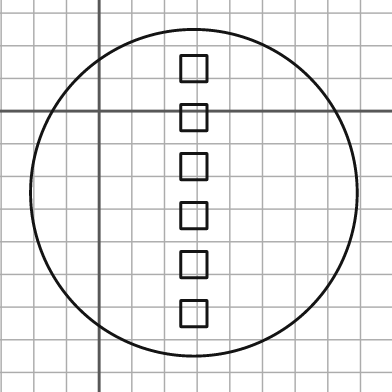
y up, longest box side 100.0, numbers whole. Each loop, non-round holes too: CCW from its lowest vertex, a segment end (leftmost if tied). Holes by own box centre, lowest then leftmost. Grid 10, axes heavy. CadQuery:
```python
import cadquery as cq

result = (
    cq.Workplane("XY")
    .moveTo(29.0, -25.0)
    .circle(50.0)
    .moveTo(25.0, -66.0)
    .lineTo(33.0, -66.0)
    .lineTo(33.0, -58.0)
    .lineTo(25.0, -58.0)
    .close()
    .moveTo(25.0, -51.0)
    .lineTo(33.0, -51.0)
    .lineTo(33.0, -43.0)
    .lineTo(25.0, -43.0)
    .close()
    .moveTo(25.0, -36.0)
    .lineTo(33.0, -36.0)
    .lineTo(33.0, -28.0)
    .lineTo(25.0, -28.0)
    .close()
    .moveTo(25.0, -21.0)
    .lineTo(33.0, -21.0)
    .lineTo(33.0, -13.0)
    .lineTo(25.0, -13.0)
    .close()
    .moveTo(25.0, -6.0)
    .lineTo(33.0, -6.0)
    .lineTo(33.0, 2.0)
    .lineTo(25.0, 2.0)
    .close()
    .moveTo(25.0, 9.0)
    .lineTo(33.0, 9.0)
    .lineTo(33.0, 17.0)
    .lineTo(25.0, 17.0)
    .close()
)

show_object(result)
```